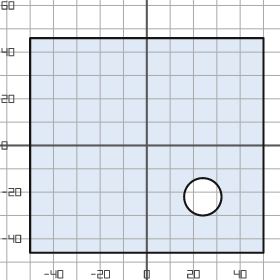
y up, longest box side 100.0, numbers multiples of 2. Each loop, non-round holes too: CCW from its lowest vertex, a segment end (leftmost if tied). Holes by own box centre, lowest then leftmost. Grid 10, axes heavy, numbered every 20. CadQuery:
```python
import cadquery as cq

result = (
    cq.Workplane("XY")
    .moveTo(-50.0, -46.0)
    .lineTo(50.0, -46.0)
    .lineTo(50.0, 46.0)
    .lineTo(-50.0, 46.0)
    .close()
    .moveTo(24.0, -22.0)
    .circle(8.0)
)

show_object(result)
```